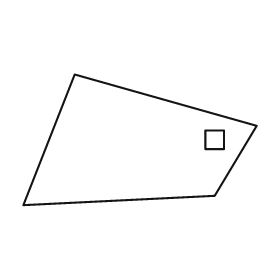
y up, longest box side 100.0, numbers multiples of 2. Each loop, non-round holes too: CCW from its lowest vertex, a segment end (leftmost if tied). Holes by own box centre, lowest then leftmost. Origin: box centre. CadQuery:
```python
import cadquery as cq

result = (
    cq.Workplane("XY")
    .moveTo(-50.0, -28.0)
    .lineTo(32.0, -24.0)
    .lineTo(50.0, 6.0)
    .lineTo(-28.0, 28.0)
    .close()
    .moveTo(28.0, -4.0)
    .lineTo(36.0, -4.0)
    .lineTo(36.0, 4.0)
    .lineTo(28.0, 4.0)
    .close()
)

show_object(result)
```